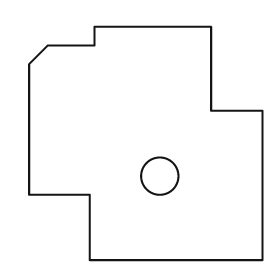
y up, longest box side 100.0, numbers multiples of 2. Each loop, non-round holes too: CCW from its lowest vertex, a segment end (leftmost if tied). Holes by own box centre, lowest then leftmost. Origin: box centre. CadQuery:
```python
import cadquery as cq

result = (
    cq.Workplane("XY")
    .moveTo(-24.0, -50.0)
    .lineTo(50.0, -50.0)
    .lineTo(50.0, 14.0)
    .lineTo(28.0, 14.0)
    .lineTo(28.0, 50.0)
    .lineTo(-22.0, 50.0)
    .lineTo(-22.0, 42.0)
    .lineTo(-42.0, 42.0)
    .lineTo(-50.0, 34.0)
    .lineTo(-50.0, -22.0)
    .lineTo(-24.0, -22.0)
    .close()
    .moveTo(6.0, -14.0)
    .circle(8.0)
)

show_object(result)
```